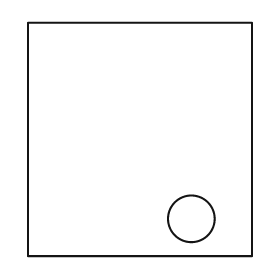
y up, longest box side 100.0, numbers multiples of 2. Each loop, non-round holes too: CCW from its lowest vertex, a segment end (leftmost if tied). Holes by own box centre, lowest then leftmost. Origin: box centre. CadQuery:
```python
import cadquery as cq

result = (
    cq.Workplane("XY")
    .moveTo(-48.0, -50.0)
    .lineTo(48.0, -50.0)
    .lineTo(48.0, 50.0)
    .lineTo(-48.0, 50.0)
    .close()
    .moveTo(22.0, -34.0)
    .circle(10.0)
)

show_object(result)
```